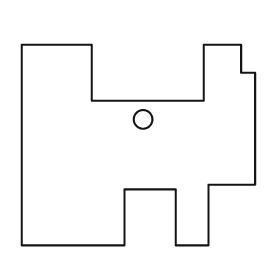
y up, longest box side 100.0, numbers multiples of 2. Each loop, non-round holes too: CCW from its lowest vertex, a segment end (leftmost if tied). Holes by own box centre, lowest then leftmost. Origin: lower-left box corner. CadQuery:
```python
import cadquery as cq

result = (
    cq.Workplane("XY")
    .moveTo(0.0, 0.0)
    .lineTo(44.0, 0.0)
    .lineTo(44.0, 24.0)
    .lineTo(66.0, 24.0)
    .lineTo(66.0, 0.0)
    .lineTo(80.0, 0.0)
    .lineTo(80.0, 26.0)
    .lineTo(100.0, 26.0)
    .lineTo(100.0, 74.0)
    .lineTo(94.0, 74.0)
    .lineTo(94.0, 86.0)
    .lineTo(78.0, 86.0)
    .lineTo(78.0, 62.0)
    .lineTo(30.0, 62.0)
    .lineTo(30.0, 86.0)
    .lineTo(0.0, 86.0)
    .close()
    .moveTo(52.0, 54.0)
    .circle(4.0)
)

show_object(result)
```